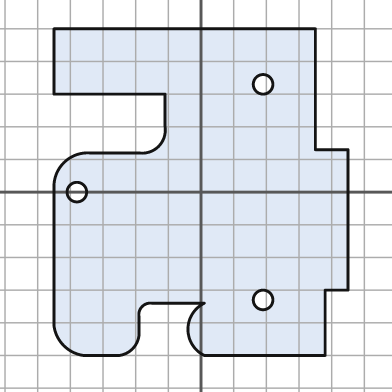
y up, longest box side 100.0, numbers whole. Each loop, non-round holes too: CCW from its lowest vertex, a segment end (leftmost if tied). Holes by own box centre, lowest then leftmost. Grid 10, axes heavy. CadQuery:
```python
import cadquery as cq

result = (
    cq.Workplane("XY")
    .moveTo(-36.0, -50.0)
    .lineTo(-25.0, -50.0)
    .threePointArc((-21.0, -48.0), (-19.0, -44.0))
    .lineTo(-19.0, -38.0)
    .threePointArc((-18.0, -35.0), (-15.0, -34.0))
    .lineTo(1.0, -34.0)
    .threePointArc((-4.0, -42.0), (1.0, -50.0))
    .lineTo(38.0, -50.0)
    .lineTo(38.0, -30.0)
    .lineTo(45.0, -30.0)
    .lineTo(45.0, 13.0)
    .lineTo(35.0, 13.0)
    .lineTo(35.0, 50.0)
    .lineTo(-45.0, 50.0)
    .lineTo(-45.0, 30.0)
    .lineTo(-11.0, 30.0)
    .lineTo(-11.0, 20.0)
    .threePointArc((-13.0, 14.0), (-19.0, 12.0))
    .lineTo(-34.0, 12.0)
    .threePointArc((-42.0, 9.0), (-45.0, 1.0))
    .lineTo(-45.0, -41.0)
    .threePointArc((-42.0, -47.0), (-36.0, -50.0))
    .close()
    .moveTo(19.0, -33.0)
    .circle(3.0)
    .moveTo(-38.0, 0.0)
    .circle(3.0)
    .moveTo(19.0, 33.0)
    .circle(3.0)
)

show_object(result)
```